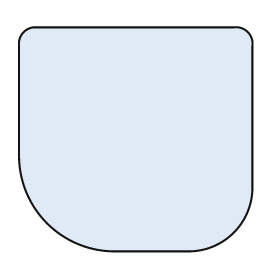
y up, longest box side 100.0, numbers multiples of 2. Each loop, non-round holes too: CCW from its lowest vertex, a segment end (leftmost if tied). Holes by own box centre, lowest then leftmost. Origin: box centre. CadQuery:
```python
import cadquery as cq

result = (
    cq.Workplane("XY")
    .moveTo(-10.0, -48.0)
    .lineTo(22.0, -48.0)
    .threePointArc((42.0, -40.0), (50.0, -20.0))
    .lineTo(50.0, 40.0)
    .threePointArc((48.0, 46.0), (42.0, 48.0))
    .lineTo(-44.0, 48.0)
    .threePointArc((-48.0, 46.0), (-50.0, 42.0))
    .lineTo(-50.0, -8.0)
    .threePointArc((-38.0, -36.0), (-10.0, -48.0))
    .close()
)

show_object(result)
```